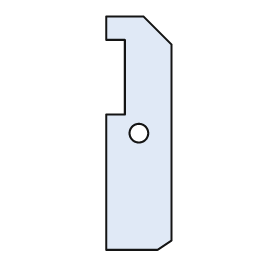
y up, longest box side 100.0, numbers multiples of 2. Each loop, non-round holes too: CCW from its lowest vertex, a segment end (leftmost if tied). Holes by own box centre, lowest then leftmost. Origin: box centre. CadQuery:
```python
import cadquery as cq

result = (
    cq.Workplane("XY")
    .moveTo(-14.0, -50.0)
    .lineTo(8.0, -50.0)
    .lineTo(14.0, -46.0)
    .lineTo(14.0, 38.0)
    .lineTo(2.0, 50.0)
    .lineTo(-14.0, 50.0)
    .lineTo(-14.0, 40.0)
    .lineTo(-6.0, 40.0)
    .lineTo(-6.0, 8.0)
    .lineTo(-14.0, 8.0)
    .close()
    .moveTo(0.0, 0.0)
    .circle(4.0)
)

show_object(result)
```